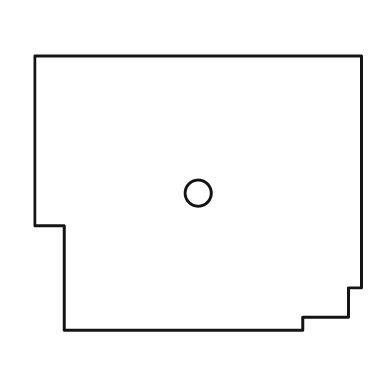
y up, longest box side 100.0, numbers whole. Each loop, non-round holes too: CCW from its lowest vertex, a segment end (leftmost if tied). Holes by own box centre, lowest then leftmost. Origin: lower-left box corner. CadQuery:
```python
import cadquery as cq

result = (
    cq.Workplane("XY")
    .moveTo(9.0, 0.0)
    .lineTo(82.0, 0.0)
    .lineTo(82.0, 4.0)
    .lineTo(96.0, 4.0)
    .lineTo(96.0, 13.0)
    .lineTo(100.0, 13.0)
    .lineTo(100.0, 84.0)
    .lineTo(0.0, 84.0)
    .lineTo(0.0, 32.0)
    .lineTo(9.0, 32.0)
    .close()
    .moveTo(50.0, 42.0)
    .circle(4.0)
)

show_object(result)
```